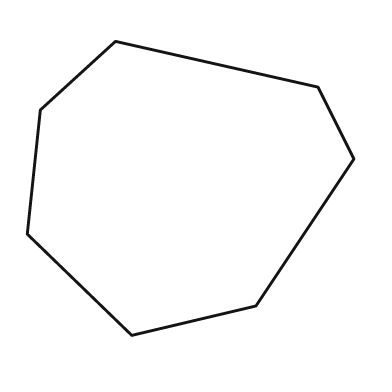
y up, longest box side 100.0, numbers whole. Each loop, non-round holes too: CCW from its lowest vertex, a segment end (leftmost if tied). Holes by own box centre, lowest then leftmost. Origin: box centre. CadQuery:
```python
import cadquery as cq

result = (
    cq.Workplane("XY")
    .moveTo(-18.0, -45.0)
    .lineTo(20.0, -36.0)
    .lineTo(50.0, 9.0)
    .lineTo(39.0, 31.0)
    .lineTo(-23.0, 45.0)
    .lineTo(-46.0, 24.0)
    .lineTo(-50.0, -14.0)
    .close()
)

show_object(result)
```